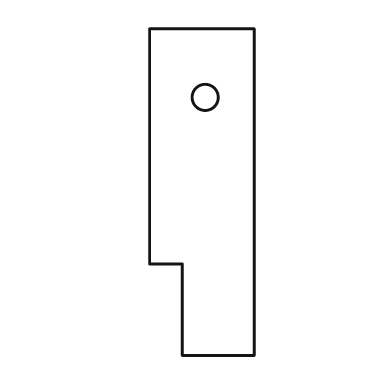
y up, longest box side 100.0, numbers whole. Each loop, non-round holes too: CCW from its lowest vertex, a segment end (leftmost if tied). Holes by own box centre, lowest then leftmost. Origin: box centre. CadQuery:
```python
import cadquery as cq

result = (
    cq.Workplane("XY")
    .moveTo(-6.0, -50.0)
    .lineTo(16.0, -50.0)
    .lineTo(16.0, 50.0)
    .lineTo(-16.0, 50.0)
    .lineTo(-16.0, -22.0)
    .lineTo(-6.0, -22.0)
    .close()
    .moveTo(1.0, 29.0)
    .circle(4.0)
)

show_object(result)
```